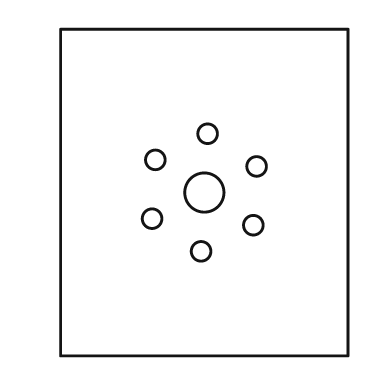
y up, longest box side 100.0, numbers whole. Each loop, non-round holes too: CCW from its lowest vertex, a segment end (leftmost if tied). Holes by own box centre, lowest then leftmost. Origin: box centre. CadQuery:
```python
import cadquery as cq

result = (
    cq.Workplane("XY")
    .moveTo(-44.0, -50.0)
    .lineTo(44.0, -50.0)
    .lineTo(44.0, 50.0)
    .lineTo(-44.0, 50.0)
    .close()
    .moveTo(-1.0, -18.0)
    .circle(3.0)
    .moveTo(15.0, -10.0)
    .circle(3.0)
    .moveTo(-16.0, -8.0)
    .circle(3.0)
    .moveTo(0.0, 0.0)
    .circle(6.0)
    .moveTo(16.0, 8.0)
    .circle(3.0)
    .moveTo(-15.0, 10.0)
    .circle(3.0)
    .moveTo(1.0, 18.0)
    .circle(3.0)
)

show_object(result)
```